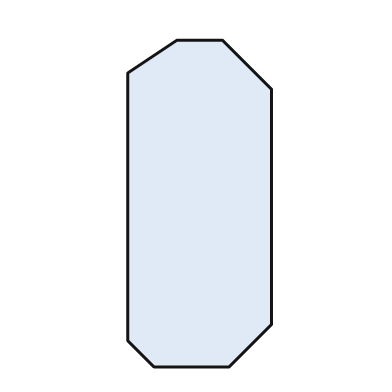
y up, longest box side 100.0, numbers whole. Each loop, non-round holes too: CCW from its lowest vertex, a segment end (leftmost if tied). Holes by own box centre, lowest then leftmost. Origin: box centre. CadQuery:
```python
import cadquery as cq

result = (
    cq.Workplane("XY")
    .moveTo(-14.0, -50.0)
    .lineTo(9.0, -50.0)
    .lineTo(22.0, -37.0)
    .lineTo(22.0, 35.0)
    .lineTo(7.0, 50.0)
    .lineTo(-7.0, 50.0)
    .lineTo(-22.0, 40.0)
    .lineTo(-22.0, -42.0)
    .close()
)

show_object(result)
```